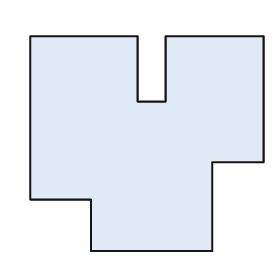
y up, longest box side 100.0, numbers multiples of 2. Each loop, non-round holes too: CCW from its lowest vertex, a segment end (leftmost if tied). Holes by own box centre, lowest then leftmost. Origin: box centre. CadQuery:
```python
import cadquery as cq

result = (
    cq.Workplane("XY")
    .moveTo(-24.0, -46.0)
    .lineTo(28.0, -46.0)
    .lineTo(28.0, -8.0)
    .lineTo(50.0, -8.0)
    .lineTo(50.0, 46.0)
    .lineTo(8.0, 46.0)
    .lineTo(8.0, 18.0)
    .lineTo(-4.0, 18.0)
    .lineTo(-4.0, 46.0)
    .lineTo(-50.0, 46.0)
    .lineTo(-50.0, -24.0)
    .lineTo(-24.0, -24.0)
    .close()
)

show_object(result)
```